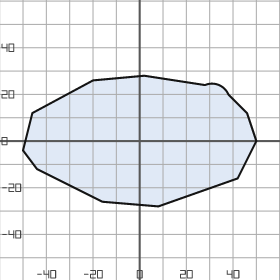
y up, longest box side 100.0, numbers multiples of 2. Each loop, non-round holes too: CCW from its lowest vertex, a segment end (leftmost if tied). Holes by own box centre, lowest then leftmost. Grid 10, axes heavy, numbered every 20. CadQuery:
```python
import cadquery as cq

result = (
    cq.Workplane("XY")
    .moveTo(8.0, -28.0)
    .lineTo(42.0, -16.0)
    .lineTo(50.0, 0.0)
    .lineTo(46.0, 12.0)
    .lineTo(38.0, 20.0)
    .threePointArc((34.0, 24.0), (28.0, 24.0))
    .lineTo(2.0, 28.0)
    .lineTo(-20.0, 26.0)
    .lineTo(-46.0, 12.0)
    .lineTo(-50.0, -4.0)
    .lineTo(-44.0, -12.0)
    .lineTo(-16.0, -26.0)
    .close()
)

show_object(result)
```